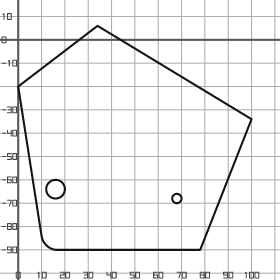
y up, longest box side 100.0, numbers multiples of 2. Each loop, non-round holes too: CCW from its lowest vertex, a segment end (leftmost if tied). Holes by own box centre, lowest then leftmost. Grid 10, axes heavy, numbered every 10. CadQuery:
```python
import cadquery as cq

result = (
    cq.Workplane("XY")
    .moveTo(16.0, -90.0)
    .lineTo(78.0, -90.0)
    .lineTo(100.0, -34.0)
    .lineTo(34.0, 6.0)
    .lineTo(0.0, -20.0)
    .lineTo(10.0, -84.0)
    .threePointArc((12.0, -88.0), (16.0, -90.0))
    .close()
    .moveTo(68.0, -68.0)
    .circle(2.0)
    .moveTo(16.0, -64.0)
    .circle(4.0)
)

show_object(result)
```